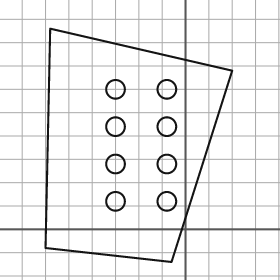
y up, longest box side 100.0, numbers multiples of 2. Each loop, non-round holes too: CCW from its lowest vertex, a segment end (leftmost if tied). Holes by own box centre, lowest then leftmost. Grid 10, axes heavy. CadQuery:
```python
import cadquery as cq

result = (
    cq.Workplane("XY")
    .moveTo(-6.0, -14.0)
    .lineTo(20.0, 68.0)
    .lineTo(-58.0, 86.0)
    .lineTo(-60.0, -8.0)
    .close()
    .moveTo(-30.0, 12.0)
    .circle(4.0)
    .moveTo(-8.0, 12.0)
    .circle(4.0)
    .moveTo(-30.0, 28.0)
    .circle(4.0)
    .moveTo(-8.0, 28.0)
    .circle(4.0)
    .moveTo(-30.0, 44.0)
    .circle(4.0)
    .moveTo(-8.0, 44.0)
    .circle(4.0)
    .moveTo(-30.0, 60.0)
    .circle(4.0)
    .moveTo(-8.0, 60.0)
    .circle(4.0)
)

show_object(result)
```